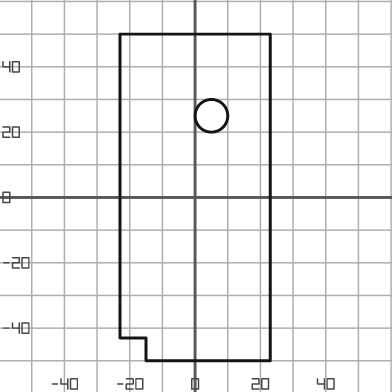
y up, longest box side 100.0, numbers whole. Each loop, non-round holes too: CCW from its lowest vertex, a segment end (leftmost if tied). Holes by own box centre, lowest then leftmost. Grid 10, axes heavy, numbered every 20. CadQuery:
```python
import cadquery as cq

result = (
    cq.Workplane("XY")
    .moveTo(-15.0, -50.0)
    .lineTo(23.0, -50.0)
    .lineTo(23.0, 50.0)
    .lineTo(-23.0, 50.0)
    .lineTo(-23.0, -43.0)
    .lineTo(-15.0, -43.0)
    .close()
    .moveTo(5.0, 25.0)
    .circle(5.0)
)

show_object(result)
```